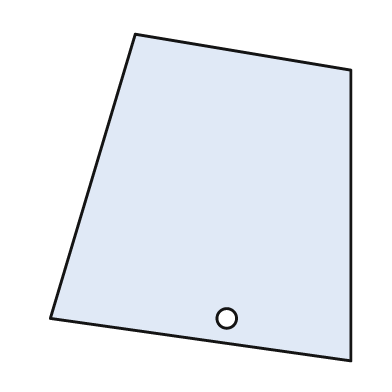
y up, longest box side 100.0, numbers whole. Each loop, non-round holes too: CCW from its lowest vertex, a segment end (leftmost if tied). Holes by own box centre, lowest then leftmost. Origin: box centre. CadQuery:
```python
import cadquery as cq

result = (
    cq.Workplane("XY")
    .moveTo(46.0, -50.0)
    .lineTo(46.0, 39.0)
    .lineTo(-20.0, 50.0)
    .lineTo(-46.0, -37.0)
    .close()
    .moveTo(8.0, -37.0)
    .circle(3.0)
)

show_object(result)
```